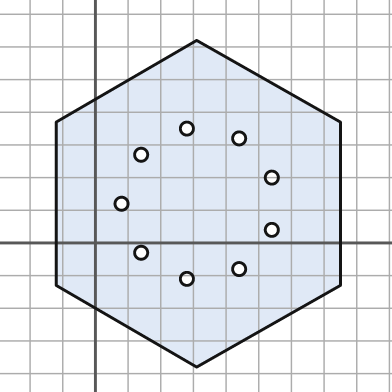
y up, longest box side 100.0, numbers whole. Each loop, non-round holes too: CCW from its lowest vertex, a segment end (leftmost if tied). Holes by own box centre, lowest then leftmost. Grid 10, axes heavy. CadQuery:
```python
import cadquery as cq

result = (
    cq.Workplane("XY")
    .moveTo(31.0, -38.0)
    .lineTo(75.0, -13.0)
    .lineTo(75.0, 37.0)
    .lineTo(31.0, 62.0)
    .lineTo(-12.0, 37.0)
    .lineTo(-12.0, -13.0)
    .close()
    .moveTo(28.0, -11.0)
    .circle(2.0)
    .moveTo(44.0, -8.0)
    .circle(2.0)
    .moveTo(14.0, -3.0)
    .circle(2.0)
    .moveTo(54.0, 4.0)
    .circle(2.0)
    .moveTo(8.0, 12.0)
    .circle(2.0)
    .moveTo(54.0, 20.0)
    .circle(2.0)
    .moveTo(14.0, 27.0)
    .circle(2.0)
    .moveTo(44.0, 32.0)
    .circle(2.0)
    .moveTo(28.0, 35.0)
    .circle(2.0)
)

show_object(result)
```